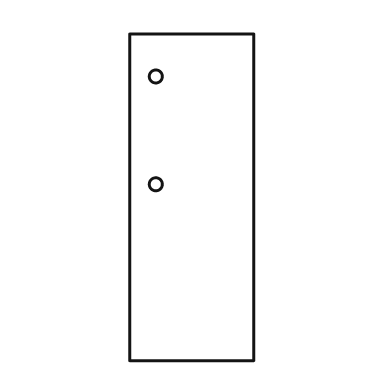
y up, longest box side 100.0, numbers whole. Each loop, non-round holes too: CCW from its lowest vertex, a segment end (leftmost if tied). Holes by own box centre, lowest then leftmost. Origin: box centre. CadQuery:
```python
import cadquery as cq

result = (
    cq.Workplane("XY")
    .moveTo(-19.0, -50.0)
    .lineTo(19.0, -50.0)
    .lineTo(19.0, 50.0)
    .lineTo(-19.0, 50.0)
    .close()
    .moveTo(-11.0, 4.0)
    .circle(2.0)
    .moveTo(-11.0, 37.0)
    .circle(2.0)
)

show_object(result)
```